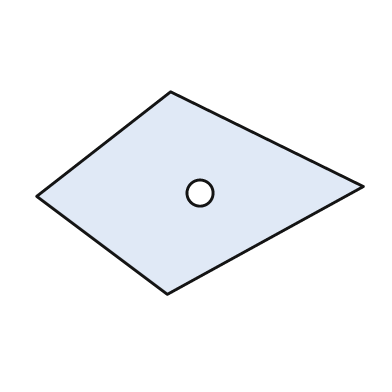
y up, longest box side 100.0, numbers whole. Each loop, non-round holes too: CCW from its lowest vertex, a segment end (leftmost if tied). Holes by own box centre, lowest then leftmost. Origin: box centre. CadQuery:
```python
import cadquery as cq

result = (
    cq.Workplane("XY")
    .moveTo(-10.0, -31.0)
    .lineTo(50.0, 2.0)
    .lineTo(-9.0, 31.0)
    .lineTo(-50.0, -1.0)
    .close()
    .moveTo(0.0, 0.0)
    .circle(4.0)
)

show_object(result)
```